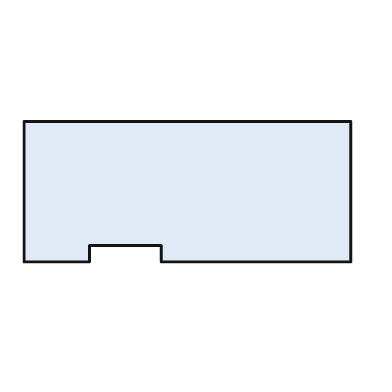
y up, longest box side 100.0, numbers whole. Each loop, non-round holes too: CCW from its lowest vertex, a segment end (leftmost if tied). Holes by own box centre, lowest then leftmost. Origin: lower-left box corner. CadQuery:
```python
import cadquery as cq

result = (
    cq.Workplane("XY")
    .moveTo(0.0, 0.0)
    .lineTo(20.0, 0.0)
    .lineTo(20.0, 5.0)
    .lineTo(42.0, 5.0)
    .lineTo(42.0, 0.0)
    .lineTo(100.0, 0.0)
    .lineTo(100.0, 43.0)
    .lineTo(0.0, 43.0)
    .close()
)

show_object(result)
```